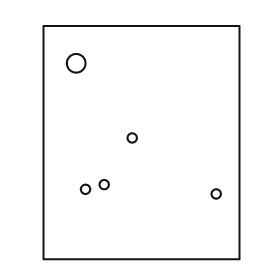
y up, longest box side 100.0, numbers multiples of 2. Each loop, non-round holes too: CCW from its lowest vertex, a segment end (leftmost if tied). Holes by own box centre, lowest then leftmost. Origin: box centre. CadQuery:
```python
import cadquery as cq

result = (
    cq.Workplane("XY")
    .moveTo(-42.0, -50.0)
    .lineTo(42.0, -50.0)
    .lineTo(42.0, 50.0)
    .lineTo(-42.0, 50.0)
    .close()
    .moveTo(32.0, -22.0)
    .circle(2.0)
    .moveTo(-24.0, -20.0)
    .circle(2.0)
    .moveTo(-16.0, -18.0)
    .circle(2.0)
    .moveTo(-4.0, 2.0)
    .circle(2.0)
    .moveTo(-28.0, 34.0)
    .circle(4.0)
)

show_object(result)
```